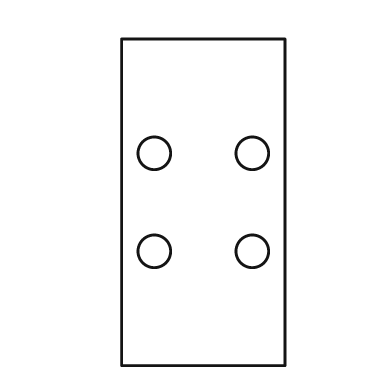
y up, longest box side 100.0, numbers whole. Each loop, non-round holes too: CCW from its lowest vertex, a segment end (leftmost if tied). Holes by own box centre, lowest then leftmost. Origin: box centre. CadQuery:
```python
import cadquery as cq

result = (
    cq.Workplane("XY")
    .moveTo(-25.0, -50.0)
    .lineTo(25.0, -50.0)
    .lineTo(25.0, 50.0)
    .lineTo(-25.0, 50.0)
    .close()
    .moveTo(-15.0, -15.0)
    .circle(5.0)
    .moveTo(15.0, -15.0)
    .circle(5.0)
    .moveTo(-15.0, 15.0)
    .circle(5.0)
    .moveTo(15.0, 15.0)
    .circle(5.0)
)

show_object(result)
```